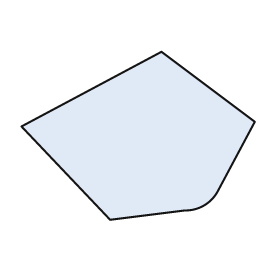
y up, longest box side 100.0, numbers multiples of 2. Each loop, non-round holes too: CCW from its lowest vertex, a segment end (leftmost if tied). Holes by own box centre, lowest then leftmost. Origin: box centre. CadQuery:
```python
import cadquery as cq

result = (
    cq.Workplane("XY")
    .moveTo(-12.0, -36.0)
    .lineTo(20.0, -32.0)
    .threePointArc((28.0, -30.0), (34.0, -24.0))
    .lineTo(50.0, 6.0)
    .lineTo(10.0, 36.0)
    .lineTo(-50.0, 4.0)
    .close()
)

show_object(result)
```